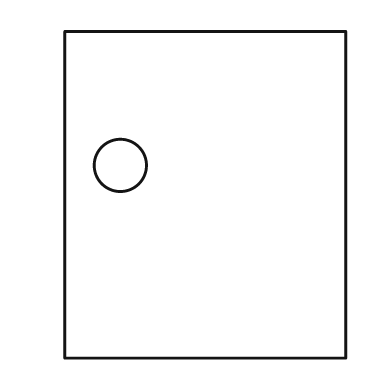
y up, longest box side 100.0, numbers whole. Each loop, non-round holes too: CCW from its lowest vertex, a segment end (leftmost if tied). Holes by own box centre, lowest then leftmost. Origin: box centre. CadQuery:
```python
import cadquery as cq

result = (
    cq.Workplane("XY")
    .moveTo(-43.0, -50.0)
    .lineTo(43.0, -50.0)
    .lineTo(43.0, 50.0)
    .lineTo(-43.0, 50.0)
    .close()
    .moveTo(-26.0, 9.0)
    .circle(8.0)
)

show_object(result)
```